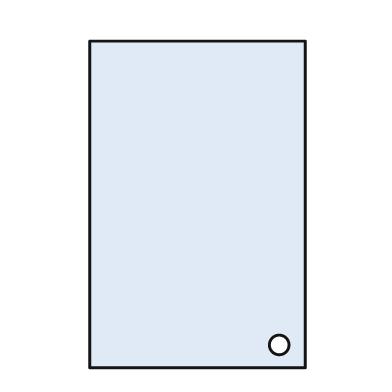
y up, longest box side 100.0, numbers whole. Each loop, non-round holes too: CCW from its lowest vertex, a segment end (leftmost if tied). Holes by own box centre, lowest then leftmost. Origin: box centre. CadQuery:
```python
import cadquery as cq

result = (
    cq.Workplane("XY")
    .moveTo(-33.0, -50.0)
    .lineTo(33.0, -50.0)
    .lineTo(33.0, 50.0)
    .lineTo(-33.0, 50.0)
    .close()
    .moveTo(25.0, -43.0)
    .circle(3.0)
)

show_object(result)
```